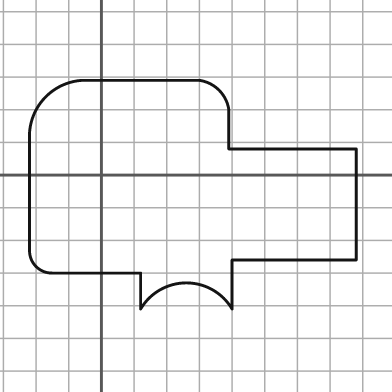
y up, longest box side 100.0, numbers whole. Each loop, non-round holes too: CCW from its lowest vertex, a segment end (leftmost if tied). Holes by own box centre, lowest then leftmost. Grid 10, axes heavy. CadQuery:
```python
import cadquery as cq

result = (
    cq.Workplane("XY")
    .moveTo(12.0, -41.0)
    .threePointArc((26.0, -33.0), (40.0, -41.0))
    .lineTo(40.0, -26.0)
    .lineTo(78.0, -26.0)
    .lineTo(78.0, 8.0)
    .lineTo(39.0, 8.0)
    .lineTo(39.0, 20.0)
    .threePointArc((36.0, 26.0), (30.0, 29.0))
    .lineTo(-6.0, 29.0)
    .threePointArc((-17.0, 24.0), (-22.0, 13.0))
    .lineTo(-22.0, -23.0)
    .threePointArc((-20.0, -28.0), (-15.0, -30.0))
    .lineTo(12.0, -30.0)
    .close()
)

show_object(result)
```